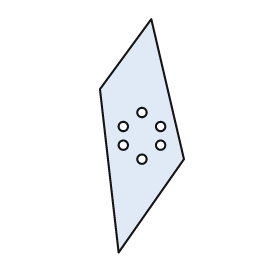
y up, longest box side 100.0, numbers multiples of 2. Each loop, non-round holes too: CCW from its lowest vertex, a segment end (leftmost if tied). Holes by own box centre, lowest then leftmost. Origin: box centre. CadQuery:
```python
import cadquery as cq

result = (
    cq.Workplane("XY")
    .moveTo(-10.0, -50.0)
    .lineTo(18.0, -10.0)
    .lineTo(4.0, 50.0)
    .lineTo(-18.0, 20.0)
    .close()
    .moveTo(0.0, -10.0)
    .circle(2.0)
    .moveTo(-8.0, -4.0)
    .circle(2.0)
    .moveTo(8.0, -4.0)
    .circle(2.0)
    .moveTo(-8.0, 4.0)
    .circle(2.0)
    .moveTo(8.0, 4.0)
    .circle(2.0)
    .moveTo(0.0, 10.0)
    .circle(2.0)
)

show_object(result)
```